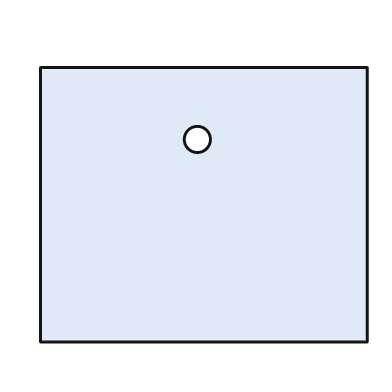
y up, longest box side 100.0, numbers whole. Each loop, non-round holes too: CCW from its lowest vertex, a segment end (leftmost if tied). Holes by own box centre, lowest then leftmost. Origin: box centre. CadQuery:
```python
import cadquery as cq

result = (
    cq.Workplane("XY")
    .moveTo(-50.0, -42.0)
    .lineTo(50.0, -42.0)
    .lineTo(50.0, 42.0)
    .lineTo(-50.0, 42.0)
    .close()
    .moveTo(-2.0, 20.0)
    .circle(4.0)
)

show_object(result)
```